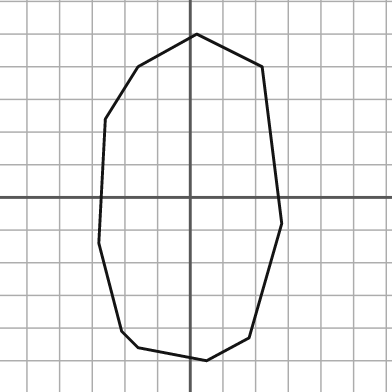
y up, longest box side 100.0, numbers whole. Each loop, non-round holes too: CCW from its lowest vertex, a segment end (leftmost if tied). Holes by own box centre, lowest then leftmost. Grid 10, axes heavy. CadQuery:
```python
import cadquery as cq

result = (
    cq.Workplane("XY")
    .moveTo(5.0, -50.0)
    .lineTo(18.0, -43.0)
    .lineTo(28.0, -8.0)
    .lineTo(22.0, 40.0)
    .lineTo(2.0, 50.0)
    .lineTo(-16.0, 40.0)
    .lineTo(-26.0, 24.0)
    .lineTo(-28.0, -14.0)
    .lineTo(-21.0, -41.0)
    .lineTo(-16.0, -46.0)
    .close()
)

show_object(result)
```